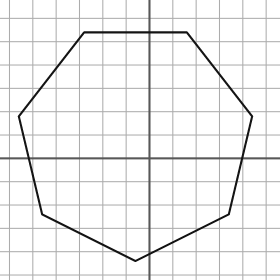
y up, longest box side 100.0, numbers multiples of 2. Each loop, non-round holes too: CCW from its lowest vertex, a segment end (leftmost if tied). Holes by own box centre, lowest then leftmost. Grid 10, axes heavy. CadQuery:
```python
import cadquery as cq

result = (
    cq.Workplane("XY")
    .moveTo(-6.0, -44.0)
    .lineTo(34.0, -24.0)
    .lineTo(44.0, 18.0)
    .lineTo(16.0, 54.0)
    .lineTo(-28.0, 54.0)
    .lineTo(-56.0, 18.0)
    .lineTo(-46.0, -24.0)
    .close()
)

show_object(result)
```